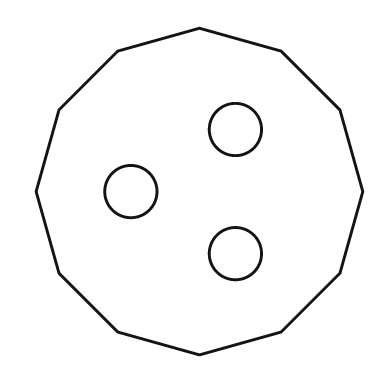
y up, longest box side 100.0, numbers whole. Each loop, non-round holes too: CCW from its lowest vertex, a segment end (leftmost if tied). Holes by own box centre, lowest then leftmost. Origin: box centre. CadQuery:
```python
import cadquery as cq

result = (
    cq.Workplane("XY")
    .moveTo(0.0, -50.0)
    .lineTo(25.0, -43.0)
    .lineTo(43.0, -25.0)
    .lineTo(50.0, 0.0)
    .lineTo(43.0, 25.0)
    .lineTo(25.0, 43.0)
    .lineTo(0.0, 50.0)
    .lineTo(-25.0, 43.0)
    .lineTo(-43.0, 25.0)
    .lineTo(-50.0, 0.0)
    .lineTo(-43.0, -25.0)
    .lineTo(-25.0, -43.0)
    .close()
    .moveTo(11.0, -19.0)
    .circle(8.0)
    .moveTo(-21.0, 0.0)
    .circle(8.0)
    .moveTo(11.0, 19.0)
    .circle(8.0)
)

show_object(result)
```